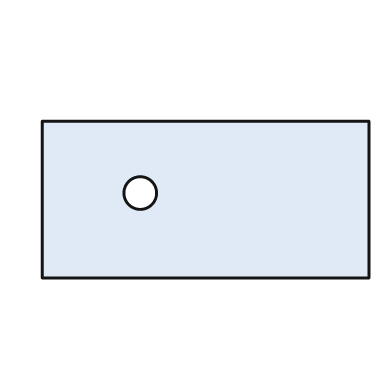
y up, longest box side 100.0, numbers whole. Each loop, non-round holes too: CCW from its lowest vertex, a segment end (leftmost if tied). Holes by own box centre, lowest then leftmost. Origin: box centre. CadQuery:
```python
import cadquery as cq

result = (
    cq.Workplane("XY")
    .moveTo(-50.0, -24.0)
    .lineTo(50.0, -24.0)
    .lineTo(50.0, 24.0)
    .lineTo(-50.0, 24.0)
    .close()
    .moveTo(-20.0, 2.0)
    .circle(5.0)
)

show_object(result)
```